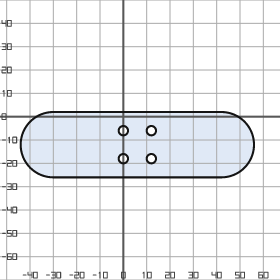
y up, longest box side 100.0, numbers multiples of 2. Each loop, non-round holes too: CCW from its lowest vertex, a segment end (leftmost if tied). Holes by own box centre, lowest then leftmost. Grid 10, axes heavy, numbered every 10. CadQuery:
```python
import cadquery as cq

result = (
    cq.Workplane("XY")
    .moveTo(-30.0, -26.0)
    .lineTo(42.0, -26.0)
    .threePointArc((56.0, -12.0), (42.0, 2.0))
    .lineTo(-30.0, 2.0)
    .threePointArc((-44.0, -12.0), (-30.0, -26.0))
    .close()
    .moveTo(0.0, -18.0)
    .circle(2.0)
    .moveTo(12.0, -18.0)
    .circle(2.0)
    .moveTo(0.0, -6.0)
    .circle(2.0)
    .moveTo(12.0, -6.0)
    .circle(2.0)
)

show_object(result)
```